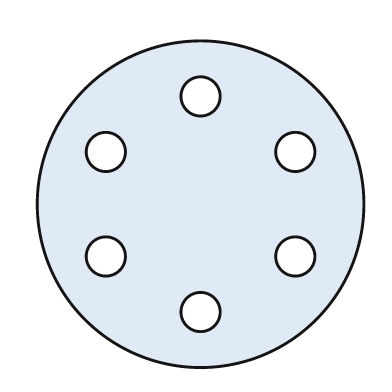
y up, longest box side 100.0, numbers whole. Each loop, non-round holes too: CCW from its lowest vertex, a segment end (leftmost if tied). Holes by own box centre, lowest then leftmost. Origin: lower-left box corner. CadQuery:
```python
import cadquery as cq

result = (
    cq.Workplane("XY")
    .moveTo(50.0, 50.0)
    .circle(50.0)
    .moveTo(50.0, 17.0)
    .circle(6.0)
    .moveTo(21.0, 34.0)
    .circle(6.0)
    .moveTo(79.0, 34.0)
    .circle(6.0)
    .moveTo(21.0, 66.0)
    .circle(6.0)
    .moveTo(79.0, 66.0)
    .circle(6.0)
    .moveTo(50.0, 83.0)
    .circle(6.0)
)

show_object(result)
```